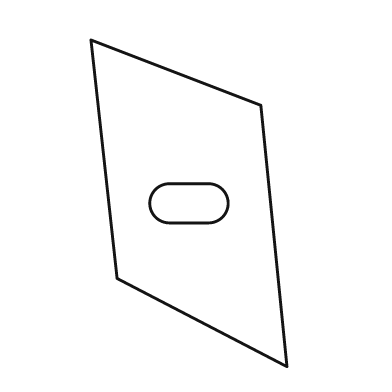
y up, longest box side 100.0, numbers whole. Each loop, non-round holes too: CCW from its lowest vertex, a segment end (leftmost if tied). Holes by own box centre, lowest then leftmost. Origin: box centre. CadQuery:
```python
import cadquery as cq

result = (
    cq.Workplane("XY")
    .moveTo(30.0, -50.0)
    .lineTo(22.0, 30.0)
    .lineTo(-30.0, 50.0)
    .lineTo(-22.0, -23.0)
    .close()
    .moveTo(-6.0, -6.0)
    .lineTo(6.0, -6.0)
    .threePointArc((12.0, 0.0), (6.0, 6.0))
    .lineTo(-6.0, 6.0)
    .threePointArc((-12.0, 0.0), (-6.0, -6.0))
    .close()
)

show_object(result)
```